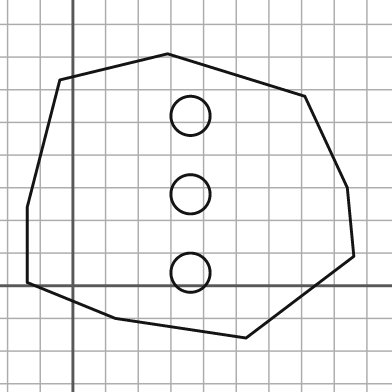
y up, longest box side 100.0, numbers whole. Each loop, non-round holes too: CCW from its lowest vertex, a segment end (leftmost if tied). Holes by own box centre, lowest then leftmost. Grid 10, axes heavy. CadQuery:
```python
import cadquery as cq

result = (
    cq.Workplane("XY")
    .moveTo(53.0, -16.0)
    .lineTo(86.0, 9.0)
    .lineTo(84.0, 30.0)
    .lineTo(71.0, 58.0)
    .lineTo(29.0, 71.0)
    .lineTo(-4.0, 63.0)
    .lineTo(-14.0, 24.0)
    .lineTo(-14.0, 1.0)
    .lineTo(13.0, -10.0)
    .close()
    .moveTo(36.0, 4.0)
    .circle(6.0)
    .moveTo(36.0, 28.0)
    .circle(6.0)
    .moveTo(36.0, 52.0)
    .circle(6.0)
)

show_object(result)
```